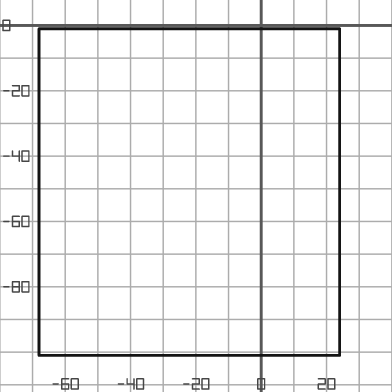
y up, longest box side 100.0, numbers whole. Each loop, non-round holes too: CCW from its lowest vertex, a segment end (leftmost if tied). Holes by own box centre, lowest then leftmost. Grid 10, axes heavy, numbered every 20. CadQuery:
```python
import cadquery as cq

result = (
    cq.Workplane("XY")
    .moveTo(-68.0, -101.0)
    .lineTo(24.0, -101.0)
    .lineTo(24.0, -1.0)
    .lineTo(-68.0, -1.0)
    .close()
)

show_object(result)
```